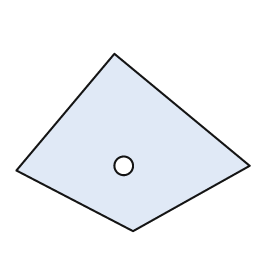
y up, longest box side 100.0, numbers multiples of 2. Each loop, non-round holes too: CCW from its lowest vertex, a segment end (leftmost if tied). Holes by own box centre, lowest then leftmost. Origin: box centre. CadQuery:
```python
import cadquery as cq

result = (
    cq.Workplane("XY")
    .moveTo(0.0, -38.0)
    .lineTo(50.0, -10.0)
    .lineTo(-8.0, 38.0)
    .lineTo(-50.0, -12.0)
    .close()
    .moveTo(-4.0, -10.0)
    .circle(4.0)
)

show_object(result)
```